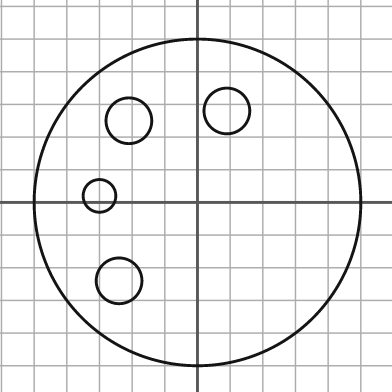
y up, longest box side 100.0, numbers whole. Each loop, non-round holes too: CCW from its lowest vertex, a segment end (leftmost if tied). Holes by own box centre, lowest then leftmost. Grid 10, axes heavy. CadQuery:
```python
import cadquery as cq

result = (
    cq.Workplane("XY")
    .moveTo(0.0, 0.0)
    .circle(50.0)
    .moveTo(-24.0, -24.0)
    .circle(7.0)
    .moveTo(-30.0, 2.0)
    .circle(5.0)
    .moveTo(-21.0, 25.0)
    .circle(7.0)
    .moveTo(9.0, 28.0)
    .circle(7.0)
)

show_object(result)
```